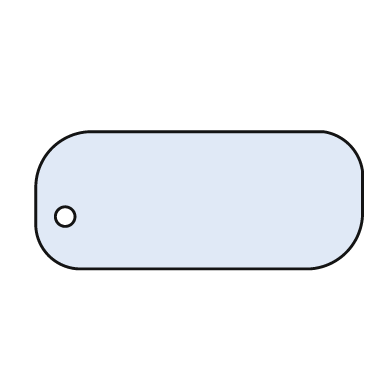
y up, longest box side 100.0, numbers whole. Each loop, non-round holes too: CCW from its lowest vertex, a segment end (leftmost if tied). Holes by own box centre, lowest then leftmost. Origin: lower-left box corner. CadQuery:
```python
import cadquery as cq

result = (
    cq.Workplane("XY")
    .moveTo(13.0, 0.0)
    .lineTo(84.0, 0.0)
    .threePointArc((95.0, 5.0), (100.0, 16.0))
    .lineTo(100.0, 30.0)
    .threePointArc((96.0, 38.0), (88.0, 42.0))
    .lineTo(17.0, 42.0)
    .threePointArc((5.0, 37.0), (0.0, 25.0))
    .lineTo(0.0, 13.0)
    .threePointArc((4.0, 4.0), (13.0, 0.0))
    .close()
    .moveTo(9.0, 16.0)
    .circle(3.0)
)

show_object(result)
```